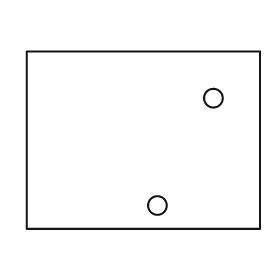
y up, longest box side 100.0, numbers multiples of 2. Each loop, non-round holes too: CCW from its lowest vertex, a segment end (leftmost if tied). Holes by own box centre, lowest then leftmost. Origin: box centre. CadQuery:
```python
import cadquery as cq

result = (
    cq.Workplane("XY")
    .moveTo(-50.0, -38.0)
    .lineTo(50.0, -38.0)
    .lineTo(50.0, 38.0)
    .lineTo(-50.0, 38.0)
    .close()
    .moveTo(6.0, -28.0)
    .circle(4.0)
    .moveTo(30.0, 18.0)
    .circle(4.0)
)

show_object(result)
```